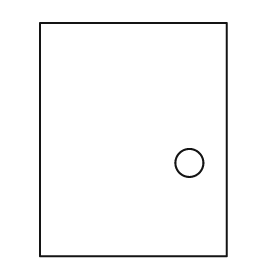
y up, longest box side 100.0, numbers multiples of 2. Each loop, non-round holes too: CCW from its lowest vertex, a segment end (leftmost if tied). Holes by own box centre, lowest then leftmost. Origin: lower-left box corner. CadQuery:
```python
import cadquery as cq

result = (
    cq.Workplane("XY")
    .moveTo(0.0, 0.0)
    .lineTo(80.0, 0.0)
    .lineTo(80.0, 100.0)
    .lineTo(0.0, 100.0)
    .close()
    .moveTo(64.0, 40.0)
    .circle(6.0)
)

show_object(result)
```